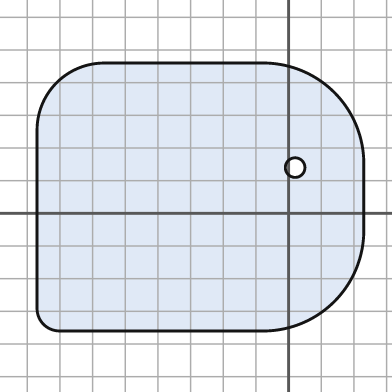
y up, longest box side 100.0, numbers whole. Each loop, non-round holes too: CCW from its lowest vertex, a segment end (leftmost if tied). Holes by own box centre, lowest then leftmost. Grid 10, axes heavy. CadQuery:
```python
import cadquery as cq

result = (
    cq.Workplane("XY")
    .moveTo(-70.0, -36.0)
    .lineTo(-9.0, -36.0)
    .threePointArc((14.0, -27.0), (23.0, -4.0))
    .lineTo(23.0, 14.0)
    .threePointArc((14.0, 37.0), (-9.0, 46.0))
    .lineTo(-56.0, 46.0)
    .threePointArc((-71.0, 40.0), (-77.0, 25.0))
    .lineTo(-77.0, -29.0)
    .threePointArc((-75.0, -34.0), (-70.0, -36.0))
    .close()
    .moveTo(2.0, 14.0)
    .circle(3.0)
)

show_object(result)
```